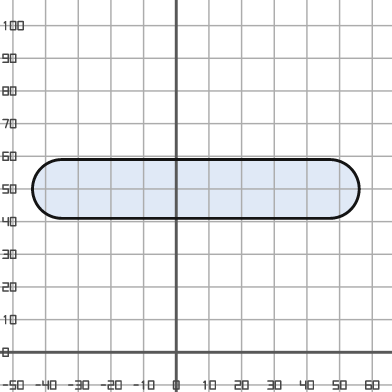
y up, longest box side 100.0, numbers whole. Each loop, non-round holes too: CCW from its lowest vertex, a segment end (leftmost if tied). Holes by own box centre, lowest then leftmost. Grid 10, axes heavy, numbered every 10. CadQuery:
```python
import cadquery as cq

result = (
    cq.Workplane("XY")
    .moveTo(-35.0, 41.0)
    .lineTo(47.0, 41.0)
    .threePointArc((56.0, 50.0), (47.0, 59.0))
    .lineTo(-35.0, 59.0)
    .threePointArc((-44.0, 50.0), (-35.0, 41.0))
    .close()
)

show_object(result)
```